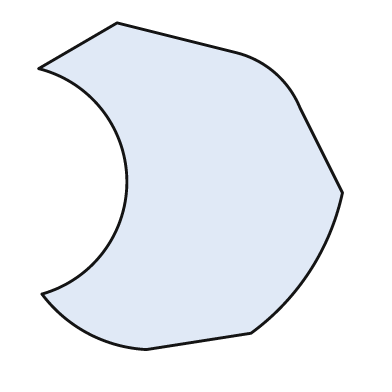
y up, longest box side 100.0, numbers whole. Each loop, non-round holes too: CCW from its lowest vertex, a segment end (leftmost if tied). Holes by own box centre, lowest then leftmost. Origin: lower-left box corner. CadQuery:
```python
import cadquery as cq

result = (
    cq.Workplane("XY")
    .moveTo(33.0, 0.0)
    .lineTo(65.0, 5.0)
    .threePointArc((83.0, 24.0), (93.0, 48.0))
    .lineTo(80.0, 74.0)
    .threePointArc((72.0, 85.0), (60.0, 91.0))
    .lineTo(24.0, 100.0)
    .lineTo(0.0, 86.0)
    .threePointArc((27.0, 52.0), (1.0, 17.0))
    .threePointArc((15.0, 5.0), (33.0, 0.0))
    .close()
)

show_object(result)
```